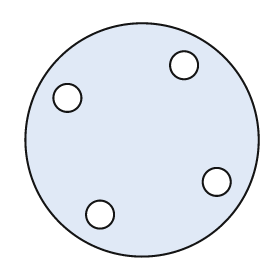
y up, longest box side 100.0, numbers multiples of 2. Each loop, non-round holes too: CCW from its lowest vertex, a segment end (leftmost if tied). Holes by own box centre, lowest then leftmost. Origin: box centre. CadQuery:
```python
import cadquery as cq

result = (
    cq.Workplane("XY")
    .moveTo(0.0, 0.0)
    .circle(50.0)
    .moveTo(-18.0, -32.0)
    .circle(6.0)
    .moveTo(32.0, -18.0)
    .circle(6.0)
    .moveTo(-32.0, 18.0)
    .circle(6.0)
    .moveTo(18.0, 32.0)
    .circle(6.0)
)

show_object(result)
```